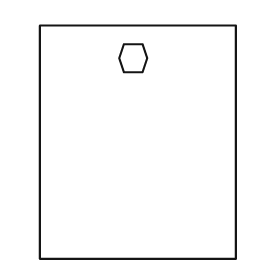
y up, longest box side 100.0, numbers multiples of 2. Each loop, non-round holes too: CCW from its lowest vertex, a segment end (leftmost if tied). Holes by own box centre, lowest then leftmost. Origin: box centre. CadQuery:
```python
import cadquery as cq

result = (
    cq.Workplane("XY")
    .moveTo(-42.0, -50.0)
    .lineTo(42.0, -50.0)
    .lineTo(42.0, 50.0)
    .lineTo(-42.0, 50.0)
    .close()
    .moveTo(-6.0, 30.0)
    .lineTo(2.0, 30.0)
    .lineTo(4.0, 36.0)
    .lineTo(2.0, 42.0)
    .lineTo(-6.0, 42.0)
    .lineTo(-8.0, 36.0)
    .close()
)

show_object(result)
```